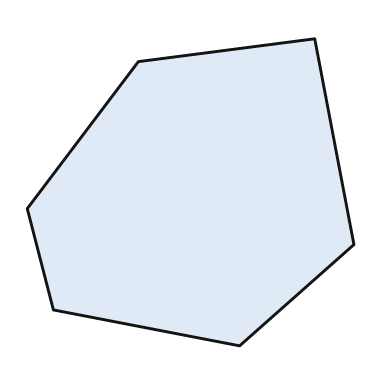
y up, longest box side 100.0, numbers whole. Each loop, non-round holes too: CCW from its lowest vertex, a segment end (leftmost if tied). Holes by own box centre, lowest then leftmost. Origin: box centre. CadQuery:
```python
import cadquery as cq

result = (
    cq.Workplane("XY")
    .moveTo(15.0, -47.0)
    .lineTo(50.0, -16.0)
    .lineTo(38.0, 47.0)
    .lineTo(-16.0, 40.0)
    .lineTo(-50.0, -5.0)
    .lineTo(-42.0, -36.0)
    .close()
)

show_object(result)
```